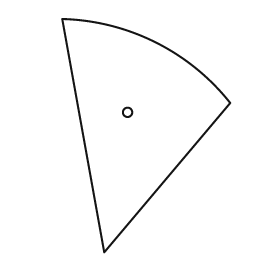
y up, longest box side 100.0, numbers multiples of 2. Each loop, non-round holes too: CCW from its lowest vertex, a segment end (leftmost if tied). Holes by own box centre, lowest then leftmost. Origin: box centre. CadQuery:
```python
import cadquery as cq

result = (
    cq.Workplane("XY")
    .moveTo(-18.0, -50.0)
    .lineTo(36.0, 14.0)
    .threePointArc((4.0, 40.0), (-36.0, 50.0))
    .close()
    .moveTo(-8.0, 10.0)
    .circle(2.0)
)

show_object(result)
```